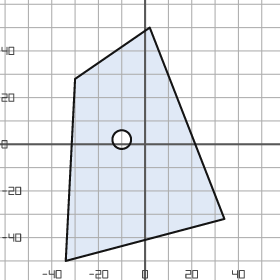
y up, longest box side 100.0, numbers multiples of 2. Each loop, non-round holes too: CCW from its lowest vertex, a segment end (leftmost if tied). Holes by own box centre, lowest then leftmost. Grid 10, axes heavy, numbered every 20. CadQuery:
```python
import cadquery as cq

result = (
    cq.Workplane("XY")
    .moveTo(-34.0, -50.0)
    .lineTo(34.0, -32.0)
    .lineTo(2.0, 50.0)
    .lineTo(-30.0, 28.0)
    .close()
    .moveTo(-10.0, 2.0)
    .circle(4.0)
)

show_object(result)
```